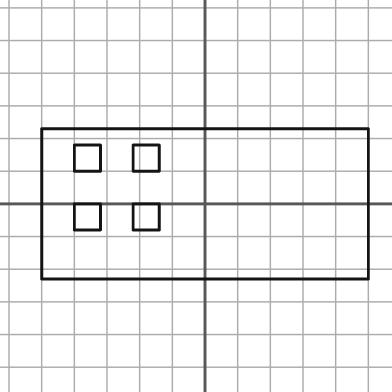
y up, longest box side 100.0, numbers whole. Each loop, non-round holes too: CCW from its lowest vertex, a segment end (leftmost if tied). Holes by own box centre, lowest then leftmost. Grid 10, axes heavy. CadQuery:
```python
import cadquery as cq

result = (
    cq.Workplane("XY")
    .moveTo(-50.0, -23.0)
    .lineTo(50.0, -23.0)
    .lineTo(50.0, 23.0)
    .lineTo(-50.0, 23.0)
    .close()
    .moveTo(-40.0, -8.0)
    .lineTo(-32.0, -8.0)
    .lineTo(-32.0, 0.0)
    .lineTo(-40.0, 0.0)
    .close()
    .moveTo(-22.0, -8.0)
    .lineTo(-14.0, -8.0)
    .lineTo(-14.0, 0.0)
    .lineTo(-22.0, 0.0)
    .close()
    .moveTo(-40.0, 10.0)
    .lineTo(-32.0, 10.0)
    .lineTo(-32.0, 18.0)
    .lineTo(-40.0, 18.0)
    .close()
    .moveTo(-22.0, 10.0)
    .lineTo(-14.0, 10.0)
    .lineTo(-14.0, 18.0)
    .lineTo(-22.0, 18.0)
    .close()
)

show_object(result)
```